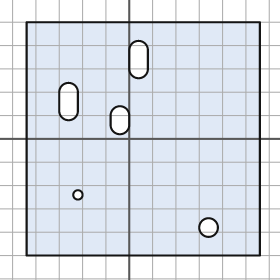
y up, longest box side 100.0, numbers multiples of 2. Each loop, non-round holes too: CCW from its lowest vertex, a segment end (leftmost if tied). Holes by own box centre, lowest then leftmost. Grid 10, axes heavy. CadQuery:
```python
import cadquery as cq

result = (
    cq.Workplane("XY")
    .moveTo(-44.0, -50.0)
    .lineTo(56.0, -50.0)
    .lineTo(56.0, 50.0)
    .lineTo(-44.0, 50.0)
    .close()
    .moveTo(34.0, -38.0)
    .circle(4.0)
    .moveTo(-22.0, -24.0)
    .circle(2.0)
    .moveTo(-8.0, 6.0)
    .threePointArc((-4.0, 2.0), (0.0, 6.0))
    .lineTo(0.0, 10.0)
    .threePointArc((-4.0, 14.0), (-8.0, 10.0))
    .close()
    .moveTo(-30.0, 12.0)
    .threePointArc((-26.0, 8.0), (-22.0, 12.0))
    .lineTo(-22.0, 20.0)
    .threePointArc((-26.0, 24.0), (-30.0, 20.0))
    .close()
    .moveTo(0.0, 30.0)
    .threePointArc((4.0, 26.0), (8.0, 30.0))
    .lineTo(8.0, 38.0)
    .threePointArc((4.0, 42.0), (0.0, 38.0))
    .close()
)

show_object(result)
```